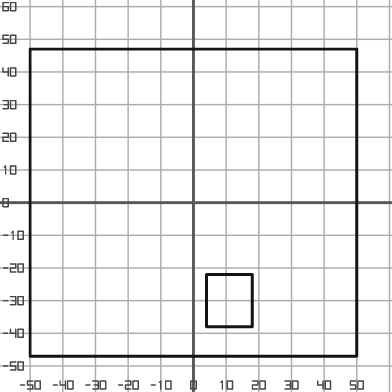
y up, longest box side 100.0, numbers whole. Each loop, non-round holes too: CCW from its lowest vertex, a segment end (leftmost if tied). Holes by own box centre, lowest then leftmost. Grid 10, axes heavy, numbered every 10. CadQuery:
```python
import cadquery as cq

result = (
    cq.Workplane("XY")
    .moveTo(-50.0, -47.0)
    .lineTo(50.0, -47.0)
    .lineTo(50.0, 47.0)
    .lineTo(-50.0, 47.0)
    .close()
    .moveTo(4.0, -38.0)
    .lineTo(18.0, -38.0)
    .lineTo(18.0, -22.0)
    .lineTo(4.0, -22.0)
    .close()
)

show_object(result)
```